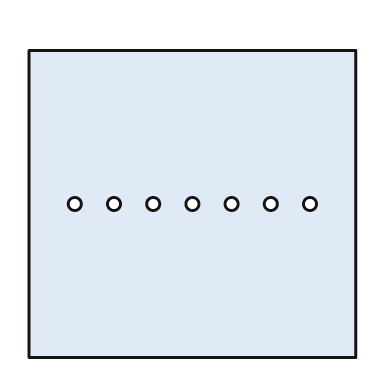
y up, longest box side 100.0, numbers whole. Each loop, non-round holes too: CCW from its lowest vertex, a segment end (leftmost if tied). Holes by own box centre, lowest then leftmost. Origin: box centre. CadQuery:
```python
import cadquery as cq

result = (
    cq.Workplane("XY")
    .moveTo(-50.0, -47.0)
    .lineTo(50.0, -47.0)
    .lineTo(50.0, 47.0)
    .lineTo(-50.0, 47.0)
    .close()
    .moveTo(-36.0, 0.0)
    .circle(2.0)
    .moveTo(-24.0, 0.0)
    .circle(2.0)
    .moveTo(-12.0, 0.0)
    .circle(2.0)
    .moveTo(0.0, 0.0)
    .circle(2.0)
    .moveTo(12.0, 0.0)
    .circle(2.0)
    .moveTo(24.0, 0.0)
    .circle(2.0)
    .moveTo(36.0, 0.0)
    .circle(2.0)
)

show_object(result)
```